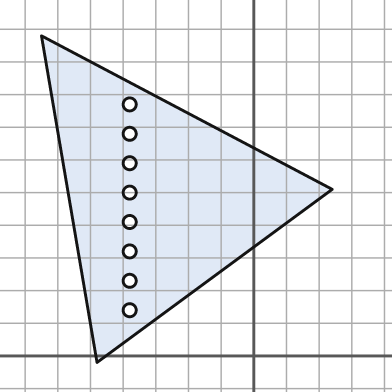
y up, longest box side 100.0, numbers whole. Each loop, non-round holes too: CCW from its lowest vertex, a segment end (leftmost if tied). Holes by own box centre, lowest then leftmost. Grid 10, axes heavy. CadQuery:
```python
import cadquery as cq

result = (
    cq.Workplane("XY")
    .moveTo(-48.0, -2.0)
    .lineTo(24.0, 51.0)
    .lineTo(-65.0, 98.0)
    .close()
    .moveTo(-38.0, 14.0)
    .circle(2.0)
    .moveTo(-38.0, 23.0)
    .circle(2.0)
    .moveTo(-38.0, 32.0)
    .circle(2.0)
    .moveTo(-38.0, 41.0)
    .circle(2.0)
    .moveTo(-38.0, 50.0)
    .circle(2.0)
    .moveTo(-38.0, 59.0)
    .circle(2.0)
    .moveTo(-38.0, 68.0)
    .circle(2.0)
    .moveTo(-38.0, 77.0)
    .circle(2.0)
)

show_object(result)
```